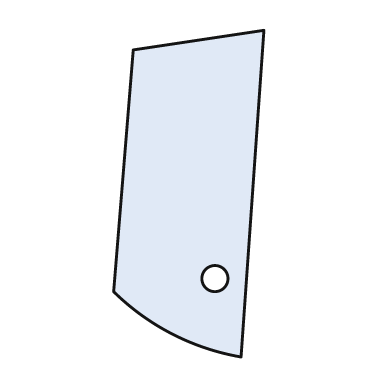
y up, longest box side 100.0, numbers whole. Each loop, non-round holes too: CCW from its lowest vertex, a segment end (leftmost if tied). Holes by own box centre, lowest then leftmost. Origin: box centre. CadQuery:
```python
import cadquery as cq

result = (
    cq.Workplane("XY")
    .moveTo(16.0, -50.0)
    .lineTo(23.0, 50.0)
    .lineTo(-17.0, 44.0)
    .lineTo(-23.0, -30.0)
    .threePointArc((-5.0, -43.0), (16.0, -50.0))
    .close()
    .moveTo(8.0, -26.0)
    .circle(4.0)
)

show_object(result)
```